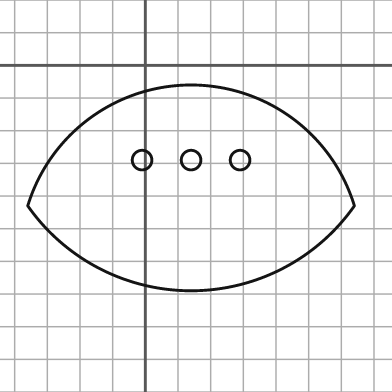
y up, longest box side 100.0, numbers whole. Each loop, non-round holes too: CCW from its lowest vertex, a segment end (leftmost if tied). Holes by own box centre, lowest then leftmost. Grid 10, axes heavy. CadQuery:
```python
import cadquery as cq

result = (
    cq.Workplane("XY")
    .moveTo(-36.0, -43.0)
    .threePointArc((14.0, -69.0), (64.0, -43.0))
    .threePointArc((14.0, -6.0), (-36.0, -43.0))
    .close()
    .moveTo(-1.0, -29.0)
    .circle(3.0)
    .moveTo(14.0, -29.0)
    .circle(3.0)
    .moveTo(29.0, -29.0)
    .circle(3.0)
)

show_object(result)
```